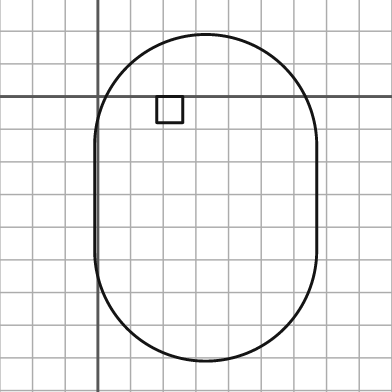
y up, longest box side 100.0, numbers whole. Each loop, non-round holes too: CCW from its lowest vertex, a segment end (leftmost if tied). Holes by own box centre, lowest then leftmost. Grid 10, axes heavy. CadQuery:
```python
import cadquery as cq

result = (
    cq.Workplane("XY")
    .moveTo(-1.0, -47.0)
    .threePointArc((33.0, -81.0), (67.0, -47.0))
    .lineTo(67.0, -15.0)
    .threePointArc((33.0, 19.0), (-1.0, -15.0))
    .close()
    .moveTo(18.0, -8.0)
    .lineTo(26.0, -8.0)
    .lineTo(26.0, 0.0)
    .lineTo(18.0, 0.0)
    .close()
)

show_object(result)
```